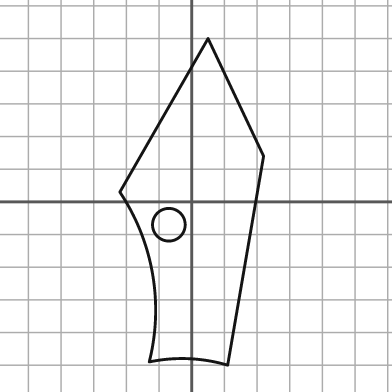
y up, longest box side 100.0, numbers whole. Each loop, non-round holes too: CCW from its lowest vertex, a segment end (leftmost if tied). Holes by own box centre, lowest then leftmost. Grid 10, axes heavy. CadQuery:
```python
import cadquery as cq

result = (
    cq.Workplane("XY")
    .moveTo(11.0, -50.0)
    .lineTo(22.0, 14.0)
    .lineTo(5.0, 50.0)
    .lineTo(-22.0, 3.0)
    .threePointArc((-12.0, -22.0), (-13.0, -49.0))
    .threePointArc((-1.0, -48.0), (11.0, -50.0))
    .close()
    .moveTo(-7.0, -7.0)
    .circle(5.0)
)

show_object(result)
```